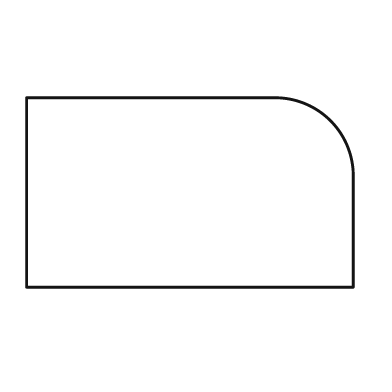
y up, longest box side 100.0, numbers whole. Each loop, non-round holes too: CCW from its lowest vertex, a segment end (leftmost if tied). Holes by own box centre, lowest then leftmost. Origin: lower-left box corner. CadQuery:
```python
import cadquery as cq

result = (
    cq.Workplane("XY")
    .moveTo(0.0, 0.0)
    .lineTo(100.0, 0.0)
    .lineTo(100.0, 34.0)
    .threePointArc((93.0, 51.0), (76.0, 58.0))
    .lineTo(0.0, 58.0)
    .close()
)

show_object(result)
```